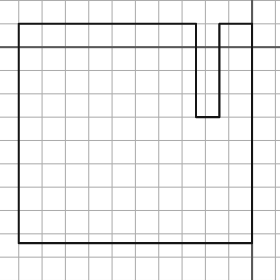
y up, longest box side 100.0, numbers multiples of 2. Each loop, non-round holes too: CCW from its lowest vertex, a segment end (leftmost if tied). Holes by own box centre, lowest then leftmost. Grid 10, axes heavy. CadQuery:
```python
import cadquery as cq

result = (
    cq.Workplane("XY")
    .moveTo(-100.0, -84.0)
    .lineTo(0.0, -84.0)
    .lineTo(0.0, 10.0)
    .lineTo(-14.0, 10.0)
    .lineTo(-14.0, -30.0)
    .lineTo(-24.0, -30.0)
    .lineTo(-24.0, 10.0)
    .lineTo(-100.0, 10.0)
    .close()
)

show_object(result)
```